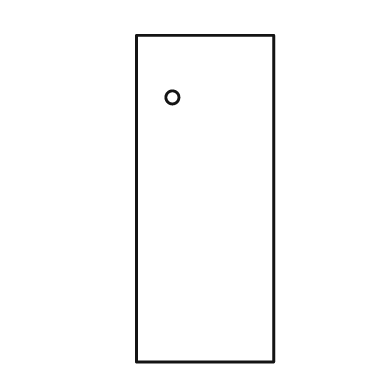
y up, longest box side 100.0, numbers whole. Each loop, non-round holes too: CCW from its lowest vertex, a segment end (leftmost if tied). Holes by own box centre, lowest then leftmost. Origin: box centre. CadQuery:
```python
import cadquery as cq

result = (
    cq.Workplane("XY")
    .moveTo(-21.0, -50.0)
    .lineTo(21.0, -50.0)
    .lineTo(21.0, 50.0)
    .lineTo(-21.0, 50.0)
    .close()
    .moveTo(-10.0, 31.0)
    .circle(2.0)
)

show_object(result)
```